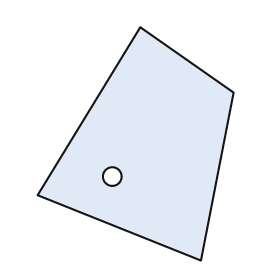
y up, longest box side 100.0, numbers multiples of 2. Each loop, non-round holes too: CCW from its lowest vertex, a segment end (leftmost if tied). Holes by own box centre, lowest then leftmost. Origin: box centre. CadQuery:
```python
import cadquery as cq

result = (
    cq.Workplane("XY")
    .moveTo(28.0, -50.0)
    .lineTo(42.0, 22.0)
    .lineTo(2.0, 50.0)
    .lineTo(-42.0, -22.0)
    .close()
    .moveTo(-10.0, -14.0)
    .circle(4.0)
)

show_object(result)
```